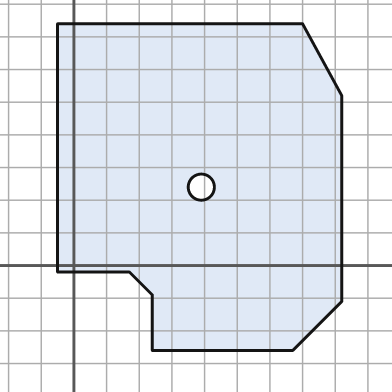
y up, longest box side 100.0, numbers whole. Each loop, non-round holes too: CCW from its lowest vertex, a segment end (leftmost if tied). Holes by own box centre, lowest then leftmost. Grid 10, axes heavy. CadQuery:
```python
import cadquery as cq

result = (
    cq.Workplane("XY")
    .moveTo(24.0, -26.0)
    .lineTo(67.0, -26.0)
    .lineTo(82.0, -11.0)
    .lineTo(82.0, 52.0)
    .lineTo(70.0, 74.0)
    .lineTo(-5.0, 74.0)
    .lineTo(-5.0, -2.0)
    .lineTo(17.0, -2.0)
    .lineTo(24.0, -9.0)
    .close()
    .moveTo(39.0, 24.0)
    .circle(4.0)
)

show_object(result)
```